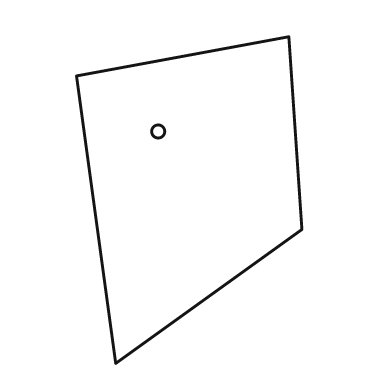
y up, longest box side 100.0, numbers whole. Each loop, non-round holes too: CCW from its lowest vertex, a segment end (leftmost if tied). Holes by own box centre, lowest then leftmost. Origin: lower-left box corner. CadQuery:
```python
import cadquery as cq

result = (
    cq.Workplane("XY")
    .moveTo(12.0, 0.0)
    .lineTo(69.0, 41.0)
    .lineTo(65.0, 100.0)
    .lineTo(0.0, 88.0)
    .close()
    .moveTo(25.0, 71.0)
    .circle(2.0)
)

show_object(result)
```